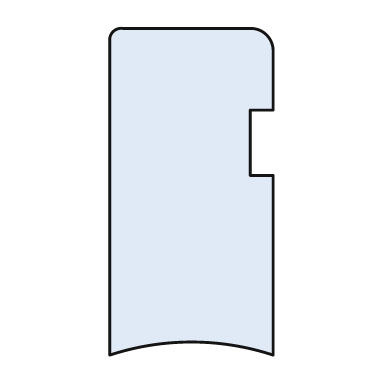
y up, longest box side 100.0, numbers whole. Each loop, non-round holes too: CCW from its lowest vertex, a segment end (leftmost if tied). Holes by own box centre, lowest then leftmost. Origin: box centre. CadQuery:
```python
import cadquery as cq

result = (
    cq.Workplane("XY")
    .moveTo(-25.0, -50.0)
    .threePointArc((0.0, -46.0), (25.0, -50.0))
    .lineTo(25.0, 5.0)
    .lineTo(18.0, 5.0)
    .lineTo(18.0, 25.0)
    .lineTo(25.0, 25.0)
    .lineTo(25.0, 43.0)
    .threePointArc((23.0, 48.0), (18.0, 50.0))
    .lineTo(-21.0, 50.0)
    .threePointArc((-24.0, 49.0), (-25.0, 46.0))
    .close()
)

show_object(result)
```